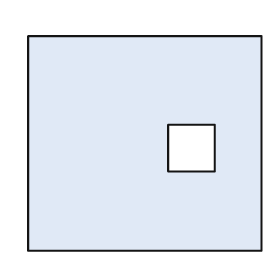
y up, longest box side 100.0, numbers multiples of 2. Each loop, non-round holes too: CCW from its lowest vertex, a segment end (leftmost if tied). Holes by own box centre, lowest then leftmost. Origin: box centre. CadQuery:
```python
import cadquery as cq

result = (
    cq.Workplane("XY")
    .moveTo(-50.0, -46.0)
    .lineTo(50.0, -46.0)
    .lineTo(50.0, 46.0)
    .lineTo(-50.0, 46.0)
    .close()
    .moveTo(10.0, -12.0)
    .lineTo(30.0, -12.0)
    .lineTo(30.0, 8.0)
    .lineTo(10.0, 8.0)
    .close()
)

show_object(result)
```